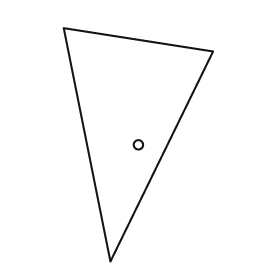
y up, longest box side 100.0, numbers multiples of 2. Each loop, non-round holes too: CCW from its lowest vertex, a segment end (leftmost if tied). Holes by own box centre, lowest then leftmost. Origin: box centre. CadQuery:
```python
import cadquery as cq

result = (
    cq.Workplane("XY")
    .moveTo(-12.0, -50.0)
    .lineTo(32.0, 40.0)
    .lineTo(-32.0, 50.0)
    .close()
    .moveTo(0.0, 0.0)
    .circle(2.0)
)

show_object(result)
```